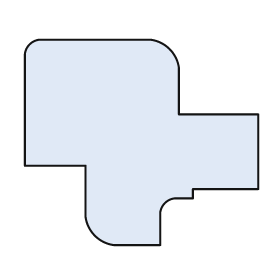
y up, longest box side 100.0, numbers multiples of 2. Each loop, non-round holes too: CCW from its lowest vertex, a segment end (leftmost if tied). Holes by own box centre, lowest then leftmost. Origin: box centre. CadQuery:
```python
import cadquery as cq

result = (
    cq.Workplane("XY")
    .moveTo(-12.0, -44.0)
    .lineTo(8.0, -44.0)
    .lineTo(8.0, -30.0)
    .threePointArc((10.0, -26.0), (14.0, -24.0))
    .lineTo(22.0, -24.0)
    .lineTo(22.0, -20.0)
    .lineTo(50.0, -20.0)
    .lineTo(50.0, 12.0)
    .lineTo(16.0, 12.0)
    .lineTo(16.0, 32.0)
    .threePointArc((12.0, 40.0), (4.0, 44.0))
    .lineTo(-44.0, 44.0)
    .threePointArc((-48.0, 42.0), (-50.0, 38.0))
    .lineTo(-50.0, -10.0)
    .lineTo(-24.0, -10.0)
    .lineTo(-24.0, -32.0)
    .threePointArc((-20.0, -40.0), (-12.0, -44.0))
    .close()
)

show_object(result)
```